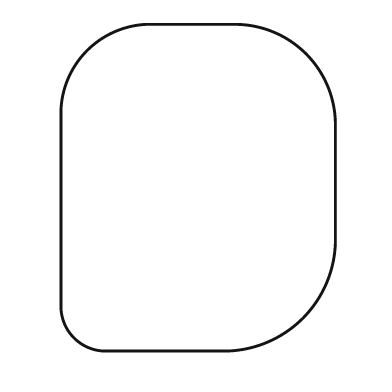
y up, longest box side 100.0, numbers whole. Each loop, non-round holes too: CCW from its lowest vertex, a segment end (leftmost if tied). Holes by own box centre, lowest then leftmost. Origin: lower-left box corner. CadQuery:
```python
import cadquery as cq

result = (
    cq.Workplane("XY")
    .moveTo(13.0, 0.0)
    .lineTo(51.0, 0.0)
    .threePointArc((74.0, 10.0), (84.0, 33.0))
    .lineTo(84.0, 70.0)
    .threePointArc((75.0, 91.0), (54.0, 100.0))
    .lineTo(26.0, 100.0)
    .threePointArc((8.0, 92.0), (0.0, 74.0))
    .lineTo(0.0, 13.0)
    .threePointArc((4.0, 4.0), (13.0, 0.0))
    .close()
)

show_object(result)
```